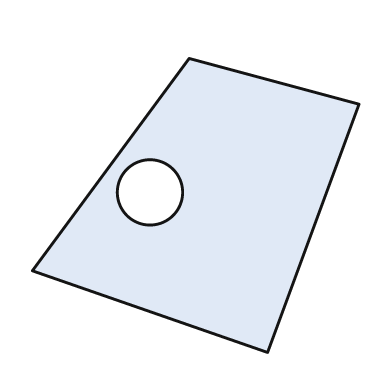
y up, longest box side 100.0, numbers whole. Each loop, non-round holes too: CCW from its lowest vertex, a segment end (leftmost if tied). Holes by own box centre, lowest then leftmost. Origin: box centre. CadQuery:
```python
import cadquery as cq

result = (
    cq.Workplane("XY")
    .moveTo(22.0, -45.0)
    .lineTo(50.0, 31.0)
    .lineTo(-2.0, 45.0)
    .lineTo(-50.0, -20.0)
    .close()
    .moveTo(-14.0, 4.0)
    .circle(10.0)
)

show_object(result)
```